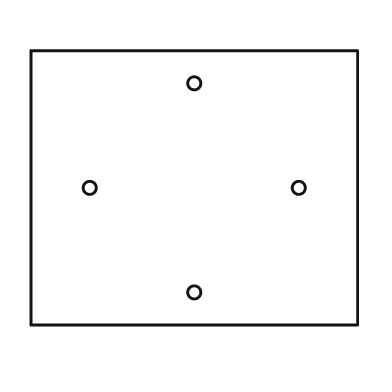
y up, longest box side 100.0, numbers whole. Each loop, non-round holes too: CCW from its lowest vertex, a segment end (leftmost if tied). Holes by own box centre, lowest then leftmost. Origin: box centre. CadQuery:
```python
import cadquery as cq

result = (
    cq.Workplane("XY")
    .moveTo(-50.0, -42.0)
    .lineTo(50.0, -42.0)
    .lineTo(50.0, 42.0)
    .lineTo(-50.0, 42.0)
    .close()
    .moveTo(0.0, -32.0)
    .circle(2.0)
    .moveTo(-32.0, 0.0)
    .circle(2.0)
    .moveTo(32.0, 0.0)
    .circle(2.0)
    .moveTo(0.0, 32.0)
    .circle(2.0)
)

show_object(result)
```